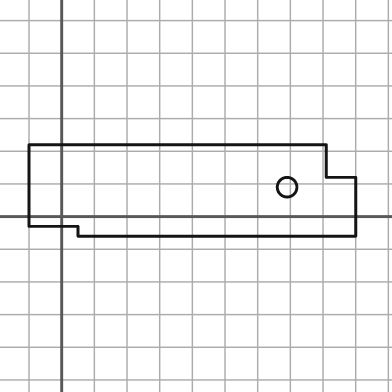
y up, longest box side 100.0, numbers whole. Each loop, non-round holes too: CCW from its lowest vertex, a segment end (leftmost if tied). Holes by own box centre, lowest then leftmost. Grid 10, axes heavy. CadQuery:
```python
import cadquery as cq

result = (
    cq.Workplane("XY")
    .moveTo(5.0, -6.0)
    .lineTo(90.0, -6.0)
    .lineTo(90.0, 12.0)
    .lineTo(81.0, 12.0)
    .lineTo(81.0, 22.0)
    .lineTo(-10.0, 22.0)
    .lineTo(-10.0, -3.0)
    .lineTo(5.0, -3.0)
    .close()
    .moveTo(69.0, 9.0)
    .circle(3.0)
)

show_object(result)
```